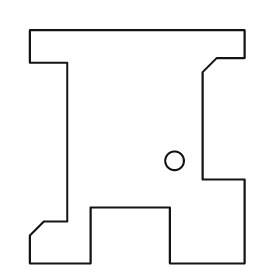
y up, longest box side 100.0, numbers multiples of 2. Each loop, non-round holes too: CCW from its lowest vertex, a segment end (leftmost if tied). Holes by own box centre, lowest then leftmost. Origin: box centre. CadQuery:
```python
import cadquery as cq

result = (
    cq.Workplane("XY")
    .moveTo(-46.0, -50.0)
    .lineTo(-20.0, -50.0)
    .lineTo(-20.0, -26.0)
    .lineTo(14.0, -26.0)
    .lineTo(14.0, -50.0)
    .lineTo(46.0, -50.0)
    .lineTo(46.0, -14.0)
    .lineTo(28.0, -14.0)
    .lineTo(28.0, 32.0)
    .lineTo(34.0, 38.0)
    .lineTo(46.0, 38.0)
    .lineTo(46.0, 50.0)
    .lineTo(-46.0, 50.0)
    .lineTo(-46.0, 36.0)
    .lineTo(-30.0, 36.0)
    .lineTo(-30.0, -32.0)
    .lineTo(-40.0, -32.0)
    .lineTo(-46.0, -38.0)
    .close()
    .moveTo(16.0, -6.0)
    .circle(4.0)
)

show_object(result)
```